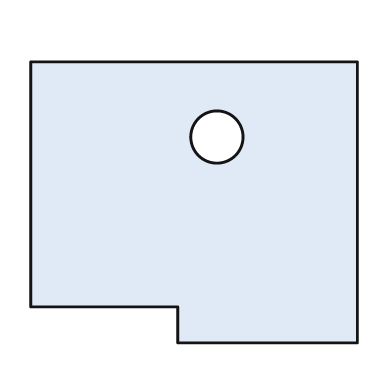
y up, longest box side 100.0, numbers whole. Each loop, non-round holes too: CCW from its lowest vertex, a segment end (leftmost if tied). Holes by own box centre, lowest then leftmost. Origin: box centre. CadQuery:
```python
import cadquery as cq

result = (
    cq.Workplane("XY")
    .moveTo(-5.0, -43.0)
    .lineTo(50.0, -43.0)
    .lineTo(50.0, 43.0)
    .lineTo(-50.0, 43.0)
    .lineTo(-50.0, -32.0)
    .lineTo(-5.0, -32.0)
    .close()
    .moveTo(7.0, 20.0)
    .circle(8.0)
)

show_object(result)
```